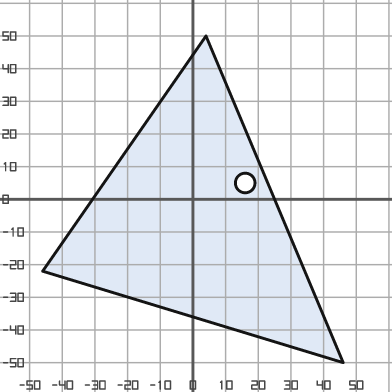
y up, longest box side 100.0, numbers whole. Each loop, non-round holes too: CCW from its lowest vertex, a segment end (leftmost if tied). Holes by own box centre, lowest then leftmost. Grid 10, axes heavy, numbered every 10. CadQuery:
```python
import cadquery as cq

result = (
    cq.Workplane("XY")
    .moveTo(46.0, -50.0)
    .lineTo(4.0, 50.0)
    .lineTo(-46.0, -22.0)
    .close()
    .moveTo(16.0, 5.0)
    .circle(3.0)
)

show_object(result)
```